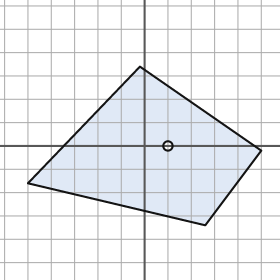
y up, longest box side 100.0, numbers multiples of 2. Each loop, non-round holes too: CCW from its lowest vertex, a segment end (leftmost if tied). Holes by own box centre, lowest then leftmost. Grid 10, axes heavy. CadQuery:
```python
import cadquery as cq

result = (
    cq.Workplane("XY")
    .moveTo(26.0, -34.0)
    .lineTo(50.0, -2.0)
    .lineTo(-2.0, 34.0)
    .lineTo(-50.0, -16.0)
    .close()
    .moveTo(10.0, 0.0)
    .circle(2.0)
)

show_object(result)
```